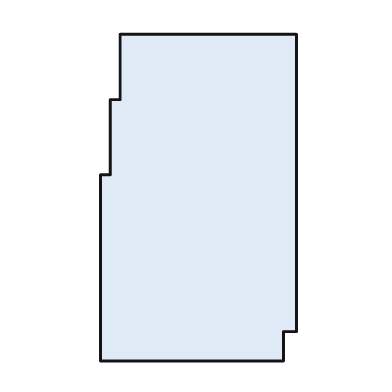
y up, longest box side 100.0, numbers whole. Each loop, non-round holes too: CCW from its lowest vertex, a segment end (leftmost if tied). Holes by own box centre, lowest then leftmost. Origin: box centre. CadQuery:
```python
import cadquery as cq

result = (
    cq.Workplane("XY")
    .moveTo(-30.0, -50.0)
    .lineTo(26.0, -50.0)
    .lineTo(26.0, -41.0)
    .lineTo(30.0, -41.0)
    .lineTo(30.0, 50.0)
    .lineTo(-24.0, 50.0)
    .lineTo(-24.0, 30.0)
    .lineTo(-27.0, 30.0)
    .lineTo(-27.0, 7.0)
    .lineTo(-30.0, 7.0)
    .close()
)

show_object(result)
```